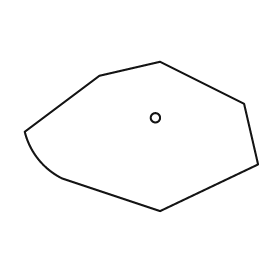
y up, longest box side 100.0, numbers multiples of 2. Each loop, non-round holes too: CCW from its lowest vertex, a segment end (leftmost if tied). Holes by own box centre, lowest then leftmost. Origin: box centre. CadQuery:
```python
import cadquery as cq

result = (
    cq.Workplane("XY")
    .moveTo(8.0, -32.0)
    .lineTo(50.0, -12.0)
    .lineTo(44.0, 14.0)
    .lineTo(8.0, 32.0)
    .lineTo(-18.0, 26.0)
    .lineTo(-50.0, 2.0)
    .threePointArc((-44.0, -10.0), (-34.0, -18.0))
    .close()
    .moveTo(6.0, 8.0)
    .circle(2.0)
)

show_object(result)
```